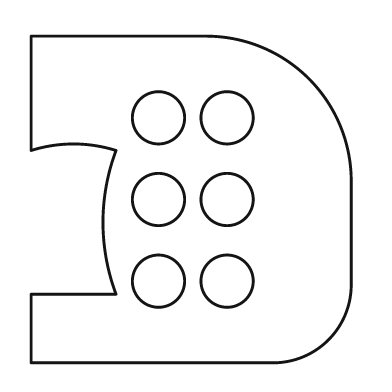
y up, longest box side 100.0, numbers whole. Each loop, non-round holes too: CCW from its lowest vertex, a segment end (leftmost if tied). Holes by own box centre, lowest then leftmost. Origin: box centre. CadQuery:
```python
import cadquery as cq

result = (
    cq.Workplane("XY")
    .moveTo(-49.0, -50.0)
    .lineTo(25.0, -50.0)
    .threePointArc((42.0, -43.0), (49.0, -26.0))
    .lineTo(49.0, 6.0)
    .threePointArc((36.0, 37.0), (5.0, 50.0))
    .lineTo(-49.0, 50.0)
    .lineTo(-49.0, 15.0)
    .threePointArc((-36.0, 17.0), (-23.0, 15.0))
    .threePointArc((-27.0, -7.0), (-23.0, -29.0))
    .lineTo(-49.0, -29.0)
    .close()
    .moveTo(-10.0, -25.0)
    .circle(8.0)
    .moveTo(11.0, -25.0)
    .circle(8.0)
    .moveTo(-10.0, 0.0)
    .circle(8.0)
    .moveTo(11.0, 0.0)
    .circle(8.0)
    .moveTo(-10.0, 25.0)
    .circle(8.0)
    .moveTo(11.0, 25.0)
    .circle(8.0)
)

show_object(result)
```